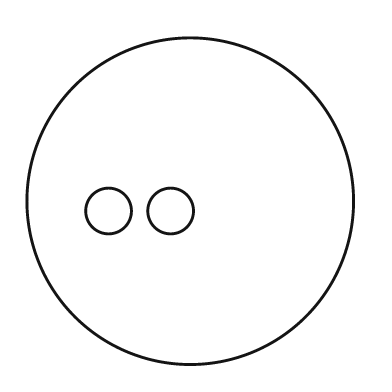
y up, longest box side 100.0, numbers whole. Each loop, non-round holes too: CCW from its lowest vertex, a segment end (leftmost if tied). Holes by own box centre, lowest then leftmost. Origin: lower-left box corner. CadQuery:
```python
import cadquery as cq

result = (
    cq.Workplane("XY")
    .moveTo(50.0, 50.0)
    .circle(50.0)
    .moveTo(25.0, 47.0)
    .circle(7.0)
    .moveTo(44.0, 47.0)
    .circle(7.0)
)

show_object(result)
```